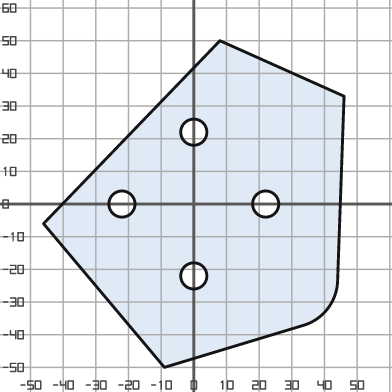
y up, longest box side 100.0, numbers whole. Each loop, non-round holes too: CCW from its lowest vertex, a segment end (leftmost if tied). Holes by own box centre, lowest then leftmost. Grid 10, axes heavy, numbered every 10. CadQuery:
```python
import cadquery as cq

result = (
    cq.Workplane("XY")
    .moveTo(-9.0, -50.0)
    .lineTo(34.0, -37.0)
    .threePointArc((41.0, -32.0), (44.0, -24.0))
    .lineTo(46.0, 33.0)
    .lineTo(8.0, 50.0)
    .lineTo(-46.0, -6.0)
    .close()
    .moveTo(0.0, -22.0)
    .circle(4.0)
    .moveTo(-22.0, 0.0)
    .circle(4.0)
    .moveTo(22.0, 0.0)
    .circle(4.0)
    .moveTo(0.0, 22.0)
    .circle(4.0)
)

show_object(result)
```